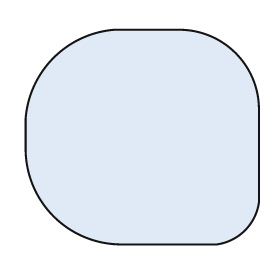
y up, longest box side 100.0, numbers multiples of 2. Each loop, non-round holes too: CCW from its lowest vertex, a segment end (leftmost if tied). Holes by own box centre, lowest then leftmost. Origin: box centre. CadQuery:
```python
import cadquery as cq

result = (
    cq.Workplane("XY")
    .moveTo(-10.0, -46.0)
    .lineTo(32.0, -46.0)
    .threePointArc((44.0, -40.0), (50.0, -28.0))
    .lineTo(50.0, 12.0)
    .threePointArc((40.0, 36.0), (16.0, 46.0))
    .lineTo(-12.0, 46.0)
    .threePointArc((-38.0, 34.0), (-50.0, 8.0))
    .lineTo(-50.0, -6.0)
    .threePointArc((-38.0, -34.0), (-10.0, -46.0))
    .close()
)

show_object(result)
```